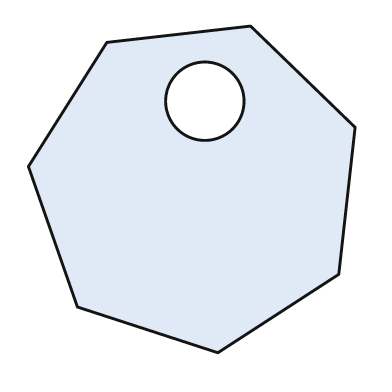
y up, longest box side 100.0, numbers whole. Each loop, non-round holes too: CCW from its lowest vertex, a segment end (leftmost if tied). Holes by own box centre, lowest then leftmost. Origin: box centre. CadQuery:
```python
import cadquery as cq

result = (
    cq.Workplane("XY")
    .moveTo(8.0, -50.0)
    .lineTo(45.0, -26.0)
    .lineTo(50.0, 19.0)
    .lineTo(18.0, 50.0)
    .lineTo(-26.0, 45.0)
    .lineTo(-50.0, 7.0)
    .lineTo(-35.0, -36.0)
    .close()
    .moveTo(4.0, 27.0)
    .circle(12.0)
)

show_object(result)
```